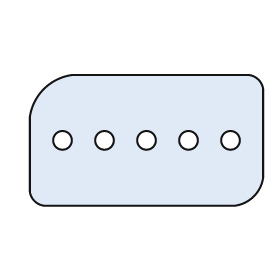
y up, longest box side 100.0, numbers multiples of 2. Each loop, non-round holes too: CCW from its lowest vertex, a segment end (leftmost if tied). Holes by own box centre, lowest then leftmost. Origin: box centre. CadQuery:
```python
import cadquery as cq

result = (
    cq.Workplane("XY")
    .moveTo(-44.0, -28.0)
    .lineTo(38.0, -28.0)
    .threePointArc((46.0, -24.0), (50.0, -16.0))
    .lineTo(50.0, 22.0)
    .threePointArc((48.0, 26.0), (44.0, 28.0))
    .lineTo(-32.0, 28.0)
    .threePointArc((-44.0, 22.0), (-50.0, 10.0))
    .lineTo(-50.0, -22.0)
    .threePointArc((-48.0, -26.0), (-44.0, -28.0))
    .close()
    .moveTo(-36.0, 0.0)
    .circle(4.0)
    .moveTo(-18.0, 0.0)
    .circle(4.0)
    .moveTo(0.0, 0.0)
    .circle(4.0)
    .moveTo(18.0, 0.0)
    .circle(4.0)
    .moveTo(36.0, 0.0)
    .circle(4.0)
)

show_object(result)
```